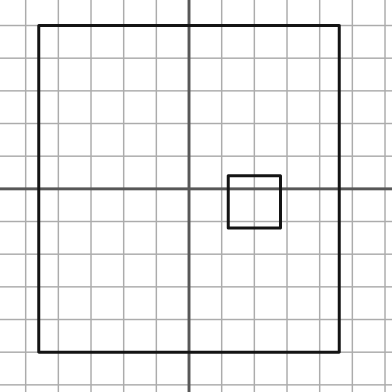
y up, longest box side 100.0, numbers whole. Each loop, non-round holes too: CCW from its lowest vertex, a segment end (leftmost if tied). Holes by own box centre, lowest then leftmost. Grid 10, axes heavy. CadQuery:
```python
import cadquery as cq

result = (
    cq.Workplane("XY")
    .moveTo(-46.0, -50.0)
    .lineTo(46.0, -50.0)
    .lineTo(46.0, 50.0)
    .lineTo(-46.0, 50.0)
    .close()
    .moveTo(12.0, -12.0)
    .lineTo(28.0, -12.0)
    .lineTo(28.0, 4.0)
    .lineTo(12.0, 4.0)
    .close()
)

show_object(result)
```